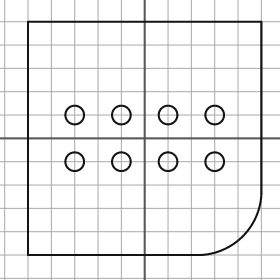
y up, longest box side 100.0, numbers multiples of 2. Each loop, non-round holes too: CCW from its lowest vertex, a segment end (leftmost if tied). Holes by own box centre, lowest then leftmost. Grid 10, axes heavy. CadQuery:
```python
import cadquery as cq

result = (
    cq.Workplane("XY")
    .moveTo(-50.0, -50.0)
    .lineTo(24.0, -50.0)
    .threePointArc((42.0, -42.0), (50.0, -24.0))
    .lineTo(50.0, 50.0)
    .lineTo(-50.0, 50.0)
    .close()
    .moveTo(-30.0, -10.0)
    .circle(4.0)
    .moveTo(-10.0, -10.0)
    .circle(4.0)
    .moveTo(10.0, -10.0)
    .circle(4.0)
    .moveTo(30.0, -10.0)
    .circle(4.0)
    .moveTo(-30.0, 10.0)
    .circle(4.0)
    .moveTo(-10.0, 10.0)
    .circle(4.0)
    .moveTo(10.0, 10.0)
    .circle(4.0)
    .moveTo(30.0, 10.0)
    .circle(4.0)
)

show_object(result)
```